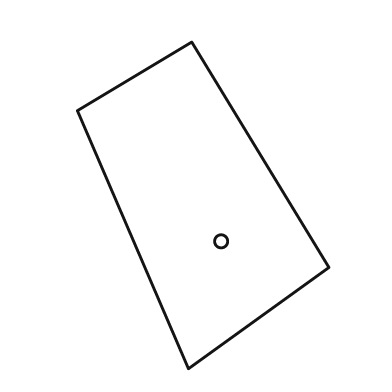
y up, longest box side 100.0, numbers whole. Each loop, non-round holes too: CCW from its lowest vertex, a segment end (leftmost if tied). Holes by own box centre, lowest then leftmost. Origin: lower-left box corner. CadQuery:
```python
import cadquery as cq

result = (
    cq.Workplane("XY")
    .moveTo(34.0, 0.0)
    .lineTo(77.0, 31.0)
    .lineTo(35.0, 100.0)
    .lineTo(0.0, 79.0)
    .close()
    .moveTo(44.0, 39.0)
    .circle(2.0)
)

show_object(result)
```